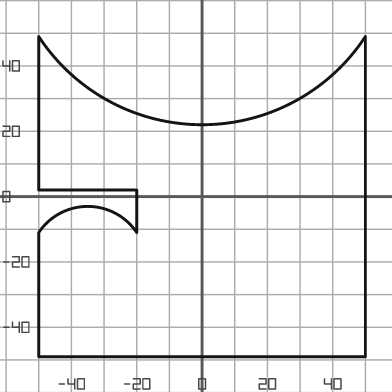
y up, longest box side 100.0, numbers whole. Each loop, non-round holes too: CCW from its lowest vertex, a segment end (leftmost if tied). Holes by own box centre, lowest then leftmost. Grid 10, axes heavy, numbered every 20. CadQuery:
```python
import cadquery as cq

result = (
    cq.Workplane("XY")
    .moveTo(-50.0, -49.0)
    .lineTo(50.0, -49.0)
    .lineTo(50.0, 49.0)
    .threePointArc((0.0, 22.0), (-50.0, 49.0))
    .lineTo(-50.0, 2.0)
    .lineTo(-20.0, 2.0)
    .lineTo(-20.0, -11.0)
    .threePointArc((-35.0, -3.0), (-50.0, -11.0))
    .close()
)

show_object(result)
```